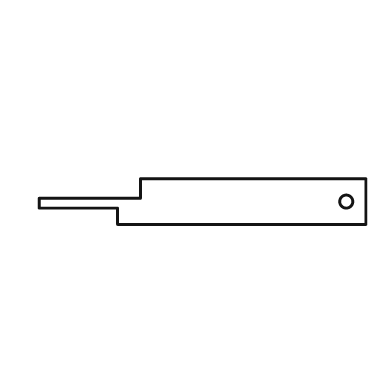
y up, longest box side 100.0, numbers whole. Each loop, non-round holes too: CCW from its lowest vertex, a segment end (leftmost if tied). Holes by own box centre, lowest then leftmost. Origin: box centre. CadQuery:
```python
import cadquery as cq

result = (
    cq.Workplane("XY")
    .moveTo(-26.0, -7.0)
    .lineTo(50.0, -7.0)
    .lineTo(50.0, 7.0)
    .lineTo(-19.0, 7.0)
    .lineTo(-19.0, 1.0)
    .lineTo(-50.0, 1.0)
    .lineTo(-50.0, -2.0)
    .lineTo(-26.0, -2.0)
    .close()
    .moveTo(44.0, 0.0)
    .circle(2.0)
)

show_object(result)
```